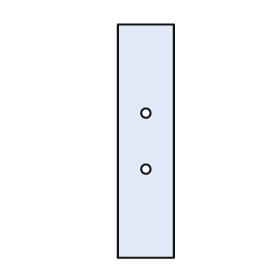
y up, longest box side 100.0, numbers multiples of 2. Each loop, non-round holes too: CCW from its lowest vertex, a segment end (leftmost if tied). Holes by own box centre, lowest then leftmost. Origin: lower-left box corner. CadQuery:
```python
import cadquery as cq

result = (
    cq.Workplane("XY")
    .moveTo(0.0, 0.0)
    .lineTo(24.0, 0.0)
    .lineTo(24.0, 100.0)
    .lineTo(0.0, 100.0)
    .close()
    .moveTo(12.0, 38.0)
    .circle(2.0)
    .moveTo(12.0, 62.0)
    .circle(2.0)
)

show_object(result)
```